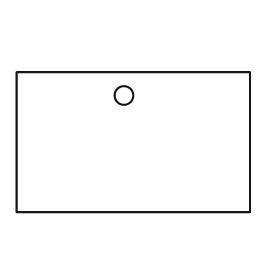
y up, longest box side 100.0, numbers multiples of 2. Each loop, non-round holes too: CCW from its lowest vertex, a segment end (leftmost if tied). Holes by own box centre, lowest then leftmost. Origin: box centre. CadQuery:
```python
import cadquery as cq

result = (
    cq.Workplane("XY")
    .moveTo(-50.0, -30.0)
    .lineTo(50.0, -30.0)
    .lineTo(50.0, 30.0)
    .lineTo(-50.0, 30.0)
    .close()
    .moveTo(-4.0, 20.0)
    .circle(4.0)
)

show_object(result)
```